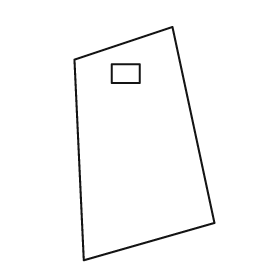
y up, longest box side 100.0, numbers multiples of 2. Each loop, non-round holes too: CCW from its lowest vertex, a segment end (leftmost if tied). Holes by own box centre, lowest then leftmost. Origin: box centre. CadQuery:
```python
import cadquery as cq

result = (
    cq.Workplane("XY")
    .moveTo(-26.0, -50.0)
    .lineTo(30.0, -34.0)
    .lineTo(12.0, 50.0)
    .lineTo(-30.0, 36.0)
    .close()
    .moveTo(-14.0, 26.0)
    .lineTo(-2.0, 26.0)
    .lineTo(-2.0, 34.0)
    .lineTo(-14.0, 34.0)
    .close()
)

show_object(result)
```